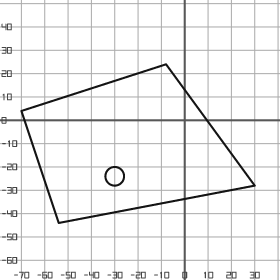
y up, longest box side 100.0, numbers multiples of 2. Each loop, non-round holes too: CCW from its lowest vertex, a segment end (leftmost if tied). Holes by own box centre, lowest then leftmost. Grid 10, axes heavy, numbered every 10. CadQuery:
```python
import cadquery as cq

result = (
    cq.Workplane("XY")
    .moveTo(-54.0, -44.0)
    .lineTo(30.0, -28.0)
    .lineTo(-8.0, 24.0)
    .lineTo(-70.0, 4.0)
    .close()
    .moveTo(-30.0, -24.0)
    .circle(4.0)
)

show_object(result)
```